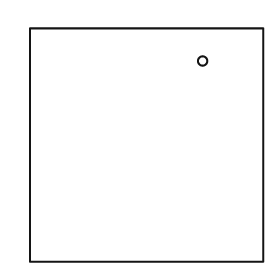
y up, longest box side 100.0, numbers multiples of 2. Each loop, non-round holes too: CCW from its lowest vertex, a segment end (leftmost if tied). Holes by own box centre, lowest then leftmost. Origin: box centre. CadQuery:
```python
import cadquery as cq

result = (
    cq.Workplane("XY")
    .moveTo(-50.0, -50.0)
    .lineTo(50.0, -50.0)
    .lineTo(50.0, 50.0)
    .lineTo(-50.0, 50.0)
    .close()
    .moveTo(24.0, 36.0)
    .circle(2.0)
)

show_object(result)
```